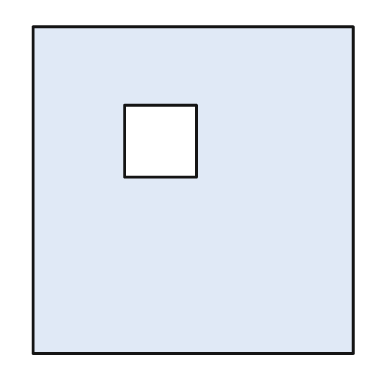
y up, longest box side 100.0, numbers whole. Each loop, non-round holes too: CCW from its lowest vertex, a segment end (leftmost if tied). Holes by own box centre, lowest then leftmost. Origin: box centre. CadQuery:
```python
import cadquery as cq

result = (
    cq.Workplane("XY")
    .moveTo(-49.0, -50.0)
    .lineTo(49.0, -50.0)
    .lineTo(49.0, 50.0)
    .lineTo(-49.0, 50.0)
    .close()
    .moveTo(-21.0, 4.0)
    .lineTo(1.0, 4.0)
    .lineTo(1.0, 26.0)
    .lineTo(-21.0, 26.0)
    .close()
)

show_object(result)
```